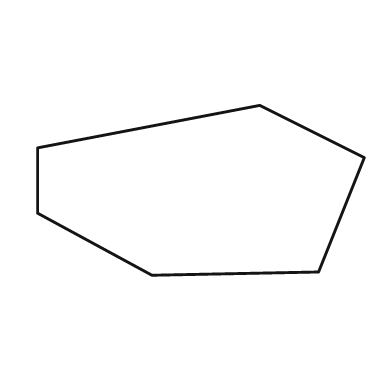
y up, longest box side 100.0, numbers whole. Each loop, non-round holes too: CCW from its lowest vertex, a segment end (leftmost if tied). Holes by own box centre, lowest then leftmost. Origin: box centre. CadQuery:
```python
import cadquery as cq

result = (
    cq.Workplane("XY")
    .moveTo(-15.0, -26.0)
    .lineTo(36.0, -25.0)
    .lineTo(50.0, 10.0)
    .lineTo(18.0, 26.0)
    .lineTo(-50.0, 13.0)
    .lineTo(-50.0, -7.0)
    .close()
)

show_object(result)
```